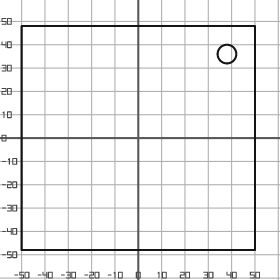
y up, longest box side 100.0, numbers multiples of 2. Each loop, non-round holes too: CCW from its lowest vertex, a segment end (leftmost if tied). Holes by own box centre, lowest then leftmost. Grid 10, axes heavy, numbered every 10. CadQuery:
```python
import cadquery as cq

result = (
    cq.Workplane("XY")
    .moveTo(-50.0, -48.0)
    .lineTo(50.0, -48.0)
    .lineTo(50.0, 48.0)
    .lineTo(-50.0, 48.0)
    .close()
    .moveTo(38.0, 36.0)
    .circle(4.0)
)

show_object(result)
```